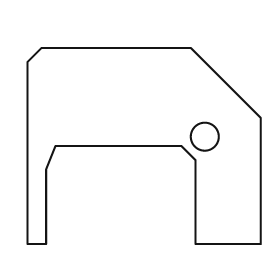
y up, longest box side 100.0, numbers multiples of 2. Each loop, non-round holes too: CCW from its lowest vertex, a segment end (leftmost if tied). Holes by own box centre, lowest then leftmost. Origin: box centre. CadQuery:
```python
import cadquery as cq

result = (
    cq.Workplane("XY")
    .moveTo(-50.0, -42.0)
    .lineTo(-42.0, -42.0)
    .lineTo(-42.0, -10.0)
    .lineTo(-38.0, 0.0)
    .lineTo(16.0, 0.0)
    .lineTo(22.0, -6.0)
    .lineTo(22.0, -42.0)
    .lineTo(50.0, -42.0)
    .lineTo(50.0, 12.0)
    .lineTo(20.0, 42.0)
    .lineTo(-44.0, 42.0)
    .lineTo(-50.0, 36.0)
    .close()
    .moveTo(26.0, 4.0)
    .circle(6.0)
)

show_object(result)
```